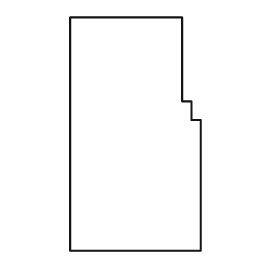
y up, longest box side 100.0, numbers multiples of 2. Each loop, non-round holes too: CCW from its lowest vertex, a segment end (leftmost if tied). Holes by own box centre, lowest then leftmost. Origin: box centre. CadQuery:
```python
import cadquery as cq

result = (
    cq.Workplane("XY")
    .moveTo(-28.0, -50.0)
    .lineTo(28.0, -50.0)
    .lineTo(28.0, 6.0)
    .lineTo(24.0, 6.0)
    .lineTo(24.0, 14.0)
    .lineTo(20.0, 14.0)
    .lineTo(20.0, 50.0)
    .lineTo(-28.0, 50.0)
    .close()
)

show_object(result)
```